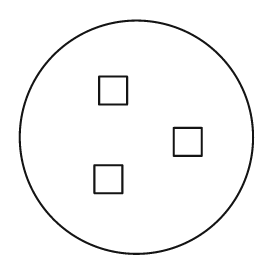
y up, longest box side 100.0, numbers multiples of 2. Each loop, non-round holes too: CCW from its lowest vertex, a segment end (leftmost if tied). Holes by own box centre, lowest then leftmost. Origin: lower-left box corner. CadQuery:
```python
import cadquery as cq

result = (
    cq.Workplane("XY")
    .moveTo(50.0, 50.0)
    .circle(50.0)
    .moveTo(32.0, 26.0)
    .lineTo(44.0, 26.0)
    .lineTo(44.0, 38.0)
    .lineTo(32.0, 38.0)
    .close()
    .moveTo(66.0, 42.0)
    .lineTo(78.0, 42.0)
    .lineTo(78.0, 54.0)
    .lineTo(66.0, 54.0)
    .close()
    .moveTo(34.0, 64.0)
    .lineTo(46.0, 64.0)
    .lineTo(46.0, 76.0)
    .lineTo(34.0, 76.0)
    .close()
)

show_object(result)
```